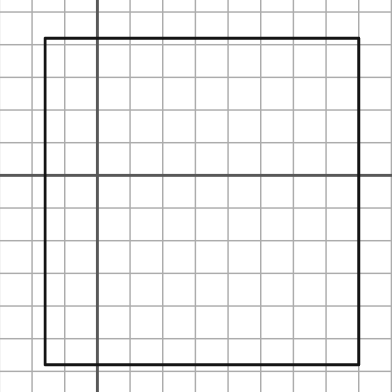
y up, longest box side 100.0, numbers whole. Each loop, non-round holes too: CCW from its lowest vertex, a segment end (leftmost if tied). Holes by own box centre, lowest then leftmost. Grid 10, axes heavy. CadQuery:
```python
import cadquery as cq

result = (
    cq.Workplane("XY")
    .moveTo(-16.0, -58.0)
    .lineTo(80.0, -58.0)
    .lineTo(80.0, 42.0)
    .lineTo(-16.0, 42.0)
    .close()
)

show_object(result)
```